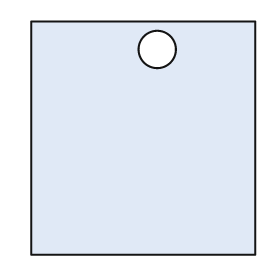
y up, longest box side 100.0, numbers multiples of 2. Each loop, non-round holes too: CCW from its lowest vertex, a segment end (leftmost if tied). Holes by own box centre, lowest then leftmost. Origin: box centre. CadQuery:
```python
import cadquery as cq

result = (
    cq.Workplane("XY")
    .moveTo(-48.0, -50.0)
    .lineTo(48.0, -50.0)
    .lineTo(48.0, 50.0)
    .lineTo(-48.0, 50.0)
    .close()
    .moveTo(6.0, 38.0)
    .circle(8.0)
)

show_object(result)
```